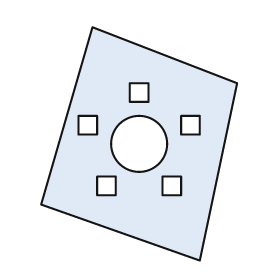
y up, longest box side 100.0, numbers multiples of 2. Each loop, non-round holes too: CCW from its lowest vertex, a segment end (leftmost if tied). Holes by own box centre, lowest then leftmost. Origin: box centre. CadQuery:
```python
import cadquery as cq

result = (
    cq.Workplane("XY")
    .moveTo(26.0, -50.0)
    .lineTo(42.0, 26.0)
    .lineTo(-20.0, 50.0)
    .lineTo(-42.0, -26.0)
    .close()
    .moveTo(-18.0, -22.0)
    .lineTo(-10.0, -22.0)
    .lineTo(-10.0, -14.0)
    .lineTo(-18.0, -14.0)
    .close()
    .moveTo(10.0, -22.0)
    .lineTo(18.0, -22.0)
    .lineTo(18.0, -14.0)
    .lineTo(10.0, -14.0)
    .close()
    .moveTo(0.0, 0.0)
    .circle(12.0)
    .moveTo(-26.0, 4.0)
    .lineTo(-18.0, 4.0)
    .lineTo(-18.0, 12.0)
    .lineTo(-26.0, 12.0)
    .close()
    .moveTo(18.0, 4.0)
    .lineTo(26.0, 4.0)
    .lineTo(26.0, 12.0)
    .lineTo(18.0, 12.0)
    .close()
    .moveTo(-4.0, 18.0)
    .lineTo(4.0, 18.0)
    .lineTo(4.0, 26.0)
    .lineTo(-4.0, 26.0)
    .close()
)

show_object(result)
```